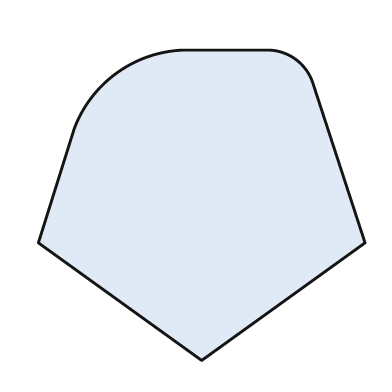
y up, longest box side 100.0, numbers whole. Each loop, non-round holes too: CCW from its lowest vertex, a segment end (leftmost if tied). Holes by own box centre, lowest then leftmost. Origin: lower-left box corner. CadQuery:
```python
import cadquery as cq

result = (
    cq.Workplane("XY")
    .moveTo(50.0, 0.0)
    .lineTo(100.0, 36.0)
    .lineTo(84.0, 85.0)
    .threePointArc((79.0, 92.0), (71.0, 95.0))
    .lineTo(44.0, 95.0)
    .threePointArc((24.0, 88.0), (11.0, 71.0))
    .lineTo(0.0, 36.0)
    .close()
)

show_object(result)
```